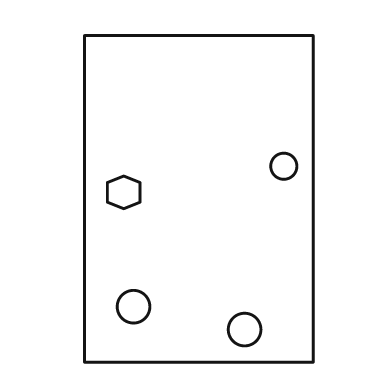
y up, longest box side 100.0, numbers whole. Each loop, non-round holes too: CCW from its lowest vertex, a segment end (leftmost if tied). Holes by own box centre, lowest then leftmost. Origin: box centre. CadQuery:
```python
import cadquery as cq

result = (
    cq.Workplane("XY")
    .moveTo(-35.0, -50.0)
    .lineTo(35.0, -50.0)
    .lineTo(35.0, 50.0)
    .lineTo(-35.0, 50.0)
    .close()
    .moveTo(14.0, -40.0)
    .circle(5.0)
    .moveTo(-20.0, -33.0)
    .circle(5.0)
    .moveTo(-23.0, -3.0)
    .lineTo(-18.0, -1.0)
    .lineTo(-18.0, 5.0)
    .lineTo(-23.0, 7.0)
    .lineTo(-28.0, 5.0)
    .lineTo(-28.0, -1.0)
    .close()
    .moveTo(26.0, 10.0)
    .circle(4.0)
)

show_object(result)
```